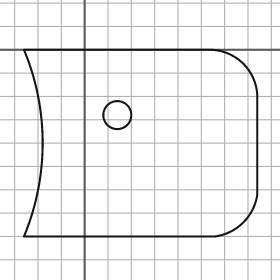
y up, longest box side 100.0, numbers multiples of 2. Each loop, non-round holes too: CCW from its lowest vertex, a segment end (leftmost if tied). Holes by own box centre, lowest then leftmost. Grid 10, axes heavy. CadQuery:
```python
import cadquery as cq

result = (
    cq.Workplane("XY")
    .moveTo(-26.0, -80.0)
    .lineTo(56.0, -80.0)
    .threePointArc((68.0, -74.0), (74.0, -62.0))
    .lineTo(74.0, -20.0)
    .threePointArc((68.0, -6.0), (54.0, 0.0))
    .lineTo(-26.0, 0.0)
    .threePointArc((-18.0, -40.0), (-26.0, -80.0))
    .close()
    .moveTo(14.0, -28.0)
    .circle(6.0)
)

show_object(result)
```